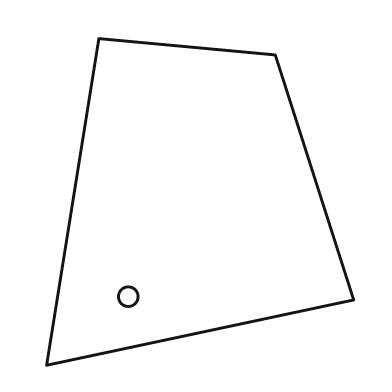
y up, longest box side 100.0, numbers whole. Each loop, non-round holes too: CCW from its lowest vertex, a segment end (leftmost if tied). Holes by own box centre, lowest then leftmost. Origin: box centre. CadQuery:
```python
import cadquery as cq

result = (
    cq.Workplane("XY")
    .moveTo(-47.0, -50.0)
    .lineTo(47.0, -30.0)
    .lineTo(23.0, 45.0)
    .lineTo(-31.0, 50.0)
    .close()
    .moveTo(-22.0, -29.0)
    .circle(3.0)
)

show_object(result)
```